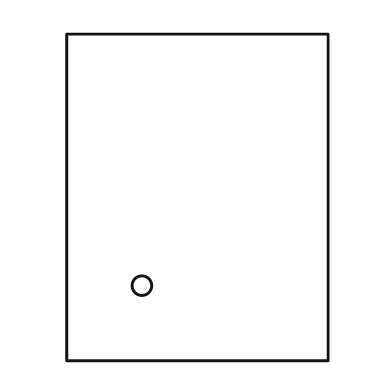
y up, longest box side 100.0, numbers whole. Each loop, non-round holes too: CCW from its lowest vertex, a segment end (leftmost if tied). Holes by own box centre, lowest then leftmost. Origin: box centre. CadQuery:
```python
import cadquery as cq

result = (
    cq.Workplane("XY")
    .moveTo(-40.0, -50.0)
    .lineTo(40.0, -50.0)
    .lineTo(40.0, 50.0)
    .lineTo(-40.0, 50.0)
    .close()
    .moveTo(-17.0, -27.0)
    .circle(3.0)
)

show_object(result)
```